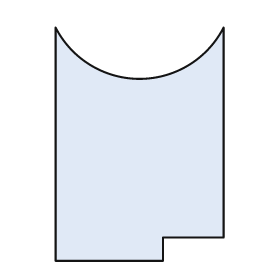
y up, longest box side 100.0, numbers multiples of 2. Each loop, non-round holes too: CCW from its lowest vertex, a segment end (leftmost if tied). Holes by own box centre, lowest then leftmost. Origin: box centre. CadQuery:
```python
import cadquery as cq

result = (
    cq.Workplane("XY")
    .moveTo(-36.0, -50.0)
    .lineTo(10.0, -50.0)
    .lineTo(10.0, -40.0)
    .lineTo(36.0, -40.0)
    .lineTo(36.0, 50.0)
    .threePointArc((0.0, 28.0), (-36.0, 50.0))
    .close()
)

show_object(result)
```